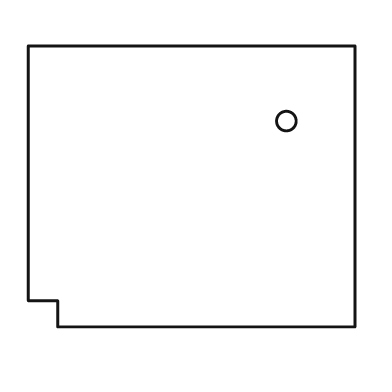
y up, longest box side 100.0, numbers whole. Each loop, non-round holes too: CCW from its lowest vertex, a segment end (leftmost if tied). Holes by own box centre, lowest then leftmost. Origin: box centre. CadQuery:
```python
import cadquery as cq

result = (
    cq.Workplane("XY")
    .moveTo(-41.0, -43.0)
    .lineTo(50.0, -43.0)
    .lineTo(50.0, 43.0)
    .lineTo(-50.0, 43.0)
    .lineTo(-50.0, -35.0)
    .lineTo(-41.0, -35.0)
    .close()
    .moveTo(29.0, 20.0)
    .circle(3.0)
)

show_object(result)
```